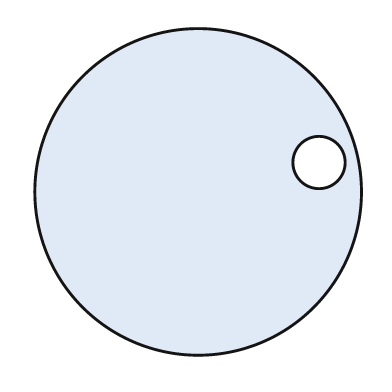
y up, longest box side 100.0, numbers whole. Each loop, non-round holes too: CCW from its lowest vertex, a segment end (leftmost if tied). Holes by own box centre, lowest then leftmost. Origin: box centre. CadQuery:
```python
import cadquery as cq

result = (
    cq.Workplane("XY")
    .moveTo(0.0, 0.0)
    .circle(50.0)
    .moveTo(37.0, 9.0)
    .circle(8.0)
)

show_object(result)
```